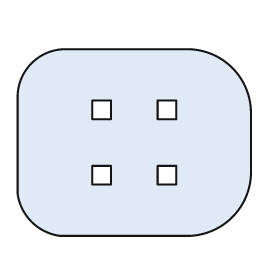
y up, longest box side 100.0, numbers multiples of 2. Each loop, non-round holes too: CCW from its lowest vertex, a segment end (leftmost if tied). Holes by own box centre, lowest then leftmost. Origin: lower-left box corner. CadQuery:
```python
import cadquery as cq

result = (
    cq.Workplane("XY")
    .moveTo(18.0, 0.0)
    .lineTo(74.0, 0.0)
    .threePointArc((92.0, 8.0), (100.0, 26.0))
    .lineTo(100.0, 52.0)
    .threePointArc((92.0, 72.0), (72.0, 80.0))
    .lineTo(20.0, 80.0)
    .threePointArc((6.0, 74.0), (0.0, 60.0))
    .lineTo(0.0, 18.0)
    .threePointArc((6.0, 6.0), (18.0, 0.0))
    .close()
    .moveTo(32.0, 22.0)
    .lineTo(40.0, 22.0)
    .lineTo(40.0, 30.0)
    .lineTo(32.0, 30.0)
    .close()
    .moveTo(60.0, 22.0)
    .lineTo(68.0, 22.0)
    .lineTo(68.0, 30.0)
    .lineTo(60.0, 30.0)
    .close()
    .moveTo(32.0, 50.0)
    .lineTo(40.0, 50.0)
    .lineTo(40.0, 58.0)
    .lineTo(32.0, 58.0)
    .close()
    .moveTo(60.0, 50.0)
    .lineTo(68.0, 50.0)
    .lineTo(68.0, 58.0)
    .lineTo(60.0, 58.0)
    .close()
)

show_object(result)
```